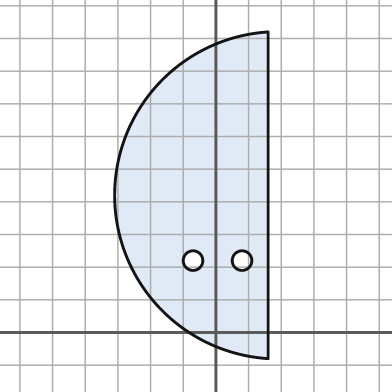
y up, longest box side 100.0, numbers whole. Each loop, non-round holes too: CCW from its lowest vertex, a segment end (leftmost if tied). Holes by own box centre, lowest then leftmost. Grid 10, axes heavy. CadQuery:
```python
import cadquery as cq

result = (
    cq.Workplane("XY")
    .moveTo(16.0, -8.0)
    .lineTo(16.0, 92.0)
    .threePointArc((-31.0, 42.0), (16.0, -8.0))
    .close()
    .moveTo(-7.0, 22.0)
    .circle(3.0)
    .moveTo(8.0, 22.0)
    .circle(3.0)
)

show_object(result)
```